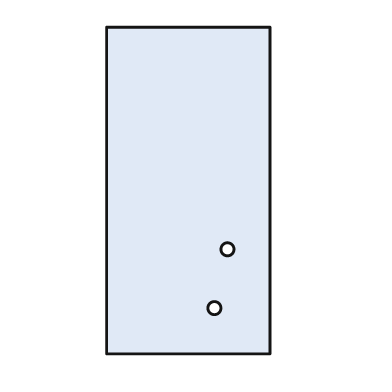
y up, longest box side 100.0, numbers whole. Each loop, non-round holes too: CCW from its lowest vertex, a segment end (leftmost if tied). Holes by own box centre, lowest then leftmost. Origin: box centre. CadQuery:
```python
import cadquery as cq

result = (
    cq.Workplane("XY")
    .moveTo(-25.0, -50.0)
    .lineTo(25.0, -50.0)
    .lineTo(25.0, 50.0)
    .lineTo(-25.0, 50.0)
    .close()
    .moveTo(8.0, -36.0)
    .circle(2.0)
    .moveTo(12.0, -18.0)
    .circle(2.0)
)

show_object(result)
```